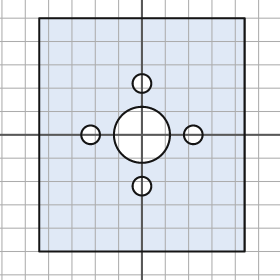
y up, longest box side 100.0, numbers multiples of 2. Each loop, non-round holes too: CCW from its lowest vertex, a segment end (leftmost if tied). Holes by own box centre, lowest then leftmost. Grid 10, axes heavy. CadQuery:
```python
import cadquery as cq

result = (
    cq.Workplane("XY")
    .moveTo(-44.0, -50.0)
    .lineTo(44.0, -50.0)
    .lineTo(44.0, 50.0)
    .lineTo(-44.0, 50.0)
    .close()
    .moveTo(0.0, -22.0)
    .circle(4.0)
    .moveTo(-22.0, 0.0)
    .circle(4.0)
    .moveTo(0.0, 0.0)
    .circle(12.0)
    .moveTo(22.0, 0.0)
    .circle(4.0)
    .moveTo(0.0, 22.0)
    .circle(4.0)
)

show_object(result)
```